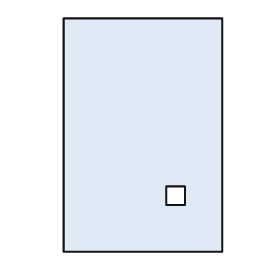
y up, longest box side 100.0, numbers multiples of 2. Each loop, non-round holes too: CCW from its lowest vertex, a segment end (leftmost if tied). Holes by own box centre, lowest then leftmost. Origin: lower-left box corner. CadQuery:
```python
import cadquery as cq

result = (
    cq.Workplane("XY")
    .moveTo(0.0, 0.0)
    .lineTo(68.0, 0.0)
    .lineTo(68.0, 100.0)
    .lineTo(0.0, 100.0)
    .close()
    .moveTo(44.0, 20.0)
    .lineTo(52.0, 20.0)
    .lineTo(52.0, 28.0)
    .lineTo(44.0, 28.0)
    .close()
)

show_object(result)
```